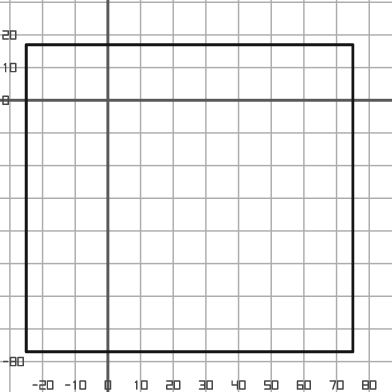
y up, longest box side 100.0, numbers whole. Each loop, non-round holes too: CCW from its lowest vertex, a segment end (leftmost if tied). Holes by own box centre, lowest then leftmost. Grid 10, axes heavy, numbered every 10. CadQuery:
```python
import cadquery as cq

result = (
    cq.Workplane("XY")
    .moveTo(-25.0, -77.0)
    .lineTo(75.0, -77.0)
    .lineTo(75.0, 17.0)
    .lineTo(-25.0, 17.0)
    .close()
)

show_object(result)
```